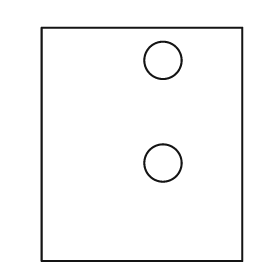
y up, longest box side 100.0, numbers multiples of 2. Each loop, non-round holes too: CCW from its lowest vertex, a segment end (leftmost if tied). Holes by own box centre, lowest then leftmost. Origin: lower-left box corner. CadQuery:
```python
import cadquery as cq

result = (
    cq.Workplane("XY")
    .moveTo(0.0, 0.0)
    .lineTo(86.0, 0.0)
    .lineTo(86.0, 100.0)
    .lineTo(0.0, 100.0)
    .close()
    .moveTo(52.0, 42.0)
    .circle(8.0)
    .moveTo(52.0, 86.0)
    .circle(8.0)
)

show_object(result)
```